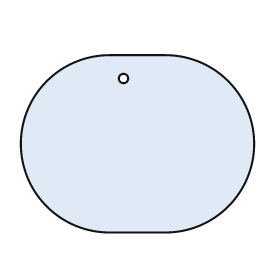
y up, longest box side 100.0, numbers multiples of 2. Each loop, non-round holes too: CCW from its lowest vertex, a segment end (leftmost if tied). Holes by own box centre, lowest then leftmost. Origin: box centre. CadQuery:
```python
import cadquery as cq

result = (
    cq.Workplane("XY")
    .moveTo(-12.0, -38.0)
    .lineTo(12.0, -38.0)
    .threePointArc((50.0, 0.0), (12.0, 38.0))
    .lineTo(-12.0, 38.0)
    .threePointArc((-50.0, 0.0), (-12.0, -38.0))
    .close()
    .moveTo(-6.0, 28.0)
    .circle(2.0)
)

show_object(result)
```